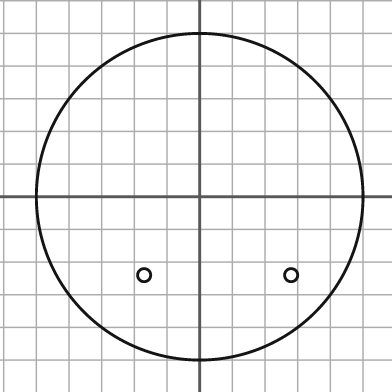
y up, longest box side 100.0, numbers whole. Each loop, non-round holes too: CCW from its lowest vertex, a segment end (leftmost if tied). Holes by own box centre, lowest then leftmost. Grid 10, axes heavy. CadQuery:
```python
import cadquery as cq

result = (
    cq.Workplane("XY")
    .moveTo(0.0, 0.0)
    .circle(50.0)
    .moveTo(-17.0, -24.0)
    .circle(2.0)
    .moveTo(28.0, -24.0)
    .circle(2.0)
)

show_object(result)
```